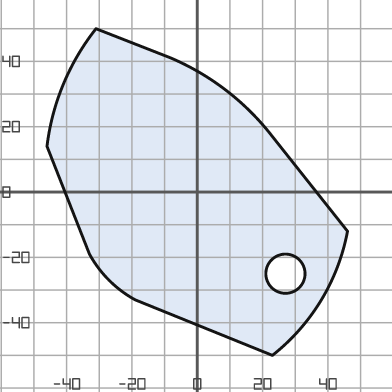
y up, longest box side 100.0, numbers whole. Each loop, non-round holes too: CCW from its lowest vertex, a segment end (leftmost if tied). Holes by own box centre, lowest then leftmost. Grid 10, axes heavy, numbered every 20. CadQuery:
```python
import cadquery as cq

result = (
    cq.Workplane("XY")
    .moveTo(23.0, -50.0)
    .threePointArc((38.0, -33.0), (46.0, -12.0))
    .lineTo(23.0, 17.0)
    .threePointArc((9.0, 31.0), (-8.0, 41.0))
    .lineTo(-31.0, 50.0)
    .threePointArc((-41.0, 33.0), (-46.0, 14.0))
    .lineTo(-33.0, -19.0)
    .threePointArc((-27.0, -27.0), (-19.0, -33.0))
    .close()
    .moveTo(27.0, -25.0)
    .circle(6.0)
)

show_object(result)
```